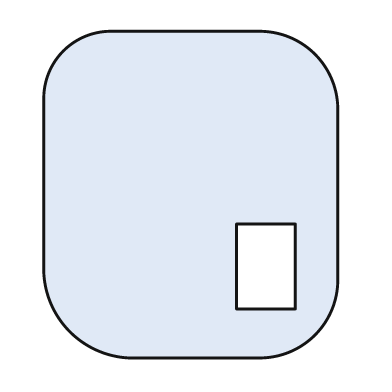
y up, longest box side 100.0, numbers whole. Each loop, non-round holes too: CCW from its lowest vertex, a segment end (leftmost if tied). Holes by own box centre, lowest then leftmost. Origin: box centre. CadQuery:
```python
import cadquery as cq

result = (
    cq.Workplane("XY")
    .moveTo(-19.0, -50.0)
    .lineTo(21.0, -50.0)
    .threePointArc((38.0, -43.0), (45.0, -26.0))
    .lineTo(45.0, 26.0)
    .threePointArc((38.0, 43.0), (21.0, 50.0))
    .lineTo(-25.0, 50.0)
    .threePointArc((-39.0, 44.0), (-45.0, 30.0))
    .lineTo(-45.0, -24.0)
    .threePointArc((-37.0, -42.0), (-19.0, -50.0))
    .close()
    .moveTo(14.0, -35.0)
    .lineTo(32.0, -35.0)
    .lineTo(32.0, -9.0)
    .lineTo(14.0, -9.0)
    .close()
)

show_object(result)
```